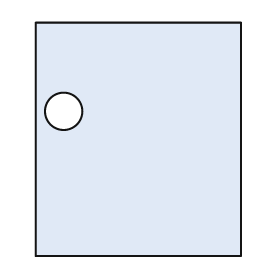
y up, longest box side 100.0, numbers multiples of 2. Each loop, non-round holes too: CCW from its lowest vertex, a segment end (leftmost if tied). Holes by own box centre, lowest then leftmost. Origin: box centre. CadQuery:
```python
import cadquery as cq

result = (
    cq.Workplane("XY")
    .moveTo(-44.0, -50.0)
    .lineTo(44.0, -50.0)
    .lineTo(44.0, 50.0)
    .lineTo(-44.0, 50.0)
    .close()
    .moveTo(-32.0, 12.0)
    .circle(8.0)
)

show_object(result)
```